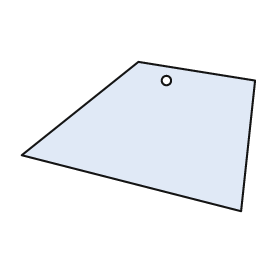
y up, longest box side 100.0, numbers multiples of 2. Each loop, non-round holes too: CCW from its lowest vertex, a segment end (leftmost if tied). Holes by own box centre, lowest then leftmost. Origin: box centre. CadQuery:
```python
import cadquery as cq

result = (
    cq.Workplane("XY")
    .moveTo(44.0, -32.0)
    .lineTo(50.0, 24.0)
    .lineTo(0.0, 32.0)
    .lineTo(-50.0, -8.0)
    .close()
    .moveTo(12.0, 24.0)
    .circle(2.0)
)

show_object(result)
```